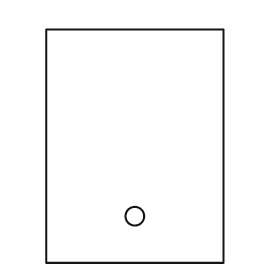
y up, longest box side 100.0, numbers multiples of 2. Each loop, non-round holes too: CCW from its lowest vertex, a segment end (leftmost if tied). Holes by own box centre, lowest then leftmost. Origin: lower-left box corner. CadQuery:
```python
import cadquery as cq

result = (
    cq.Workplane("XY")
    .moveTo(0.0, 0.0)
    .lineTo(76.0, 0.0)
    .lineTo(76.0, 100.0)
    .lineTo(0.0, 100.0)
    .close()
    .moveTo(38.0, 20.0)
    .circle(4.0)
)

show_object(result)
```